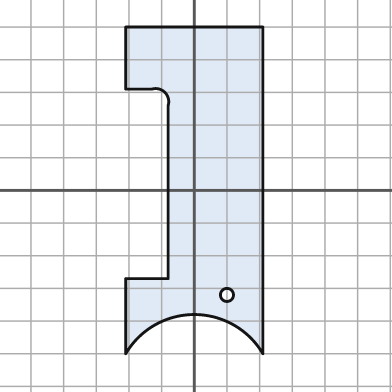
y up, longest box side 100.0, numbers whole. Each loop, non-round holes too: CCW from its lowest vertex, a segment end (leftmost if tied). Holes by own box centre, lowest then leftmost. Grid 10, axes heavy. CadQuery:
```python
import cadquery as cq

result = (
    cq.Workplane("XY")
    .moveTo(-21.0, -50.0)
    .threePointArc((0.0, -38.0), (21.0, -50.0))
    .lineTo(21.0, 50.0)
    .lineTo(-21.0, 50.0)
    .lineTo(-21.0, 31.0)
    .lineTo(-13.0, 31.0)
    .threePointArc((-9.0, 30.0), (-8.0, 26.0))
    .lineTo(-8.0, -27.0)
    .lineTo(-21.0, -27.0)
    .close()
    .moveTo(10.0, -32.0)
    .circle(2.0)
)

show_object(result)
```